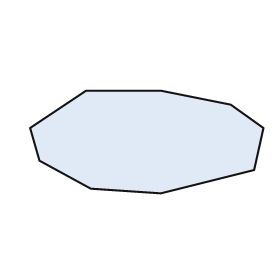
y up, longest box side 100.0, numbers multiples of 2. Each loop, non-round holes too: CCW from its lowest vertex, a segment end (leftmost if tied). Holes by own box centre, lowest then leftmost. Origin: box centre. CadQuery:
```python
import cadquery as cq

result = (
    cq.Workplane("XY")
    .moveTo(6.0, -22.0)
    .lineTo(46.0, -12.0)
    .lineTo(50.0, 6.0)
    .lineTo(36.0, 16.0)
    .lineTo(6.0, 22.0)
    .lineTo(-26.0, 22.0)
    .lineTo(-50.0, 6.0)
    .lineTo(-46.0, -8.0)
    .lineTo(-24.0, -20.0)
    .close()
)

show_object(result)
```